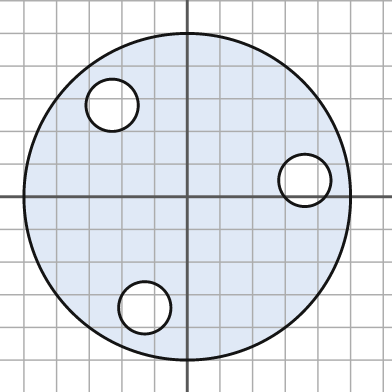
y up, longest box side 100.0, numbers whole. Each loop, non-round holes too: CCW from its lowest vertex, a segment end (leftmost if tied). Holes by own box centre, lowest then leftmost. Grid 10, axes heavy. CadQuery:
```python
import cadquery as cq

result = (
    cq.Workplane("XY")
    .moveTo(0.0, 0.0)
    .circle(50.0)
    .moveTo(-13.0, -34.0)
    .circle(8.0)
    .moveTo(36.0, 5.0)
    .circle(8.0)
    .moveTo(-23.0, 28.0)
    .circle(8.0)
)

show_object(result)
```